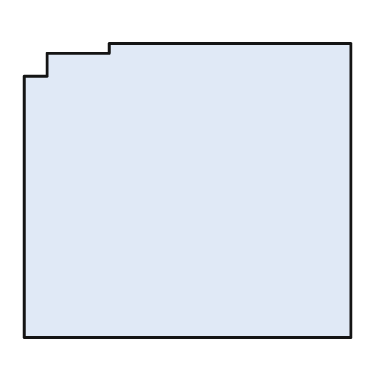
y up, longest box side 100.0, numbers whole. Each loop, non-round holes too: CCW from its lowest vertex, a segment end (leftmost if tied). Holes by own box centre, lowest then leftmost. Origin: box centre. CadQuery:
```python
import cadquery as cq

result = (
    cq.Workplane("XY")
    .moveTo(-50.0, -45.0)
    .lineTo(50.0, -45.0)
    .lineTo(50.0, 45.0)
    .lineTo(-24.0, 45.0)
    .lineTo(-24.0, 42.0)
    .lineTo(-43.0, 42.0)
    .lineTo(-43.0, 35.0)
    .lineTo(-50.0, 35.0)
    .close()
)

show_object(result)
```